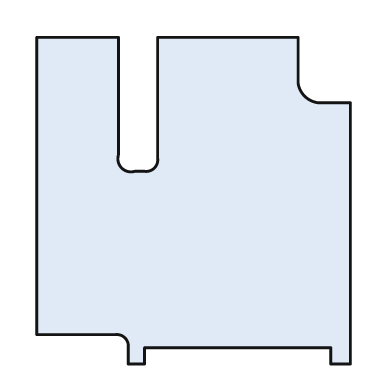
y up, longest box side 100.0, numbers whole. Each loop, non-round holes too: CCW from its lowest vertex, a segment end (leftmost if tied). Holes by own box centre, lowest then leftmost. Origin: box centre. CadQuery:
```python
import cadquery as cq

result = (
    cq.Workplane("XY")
    .moveTo(-20.0, -50.0)
    .lineTo(-15.0, -50.0)
    .lineTo(-15.0, -45.0)
    .lineTo(42.0, -45.0)
    .lineTo(42.0, -50.0)
    .lineTo(48.0, -50.0)
    .lineTo(48.0, 30.0)
    .lineTo(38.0, 30.0)
    .threePointArc((34.0, 32.0), (32.0, 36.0))
    .lineTo(32.0, 50.0)
    .lineTo(-11.0, 50.0)
    .lineTo(-11.0, 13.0)
    .threePointArc((-12.0, 10.0), (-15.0, 9.0))
    .lineTo(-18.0, 9.0)
    .threePointArc((-22.0, 10.0), (-23.0, 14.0))
    .lineTo(-23.0, 50.0)
    .lineTo(-48.0, 50.0)
    .lineTo(-48.0, -41.0)
    .lineTo(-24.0, -41.0)
    .threePointArc((-21.0, -42.0), (-20.0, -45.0))
    .close()
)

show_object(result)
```